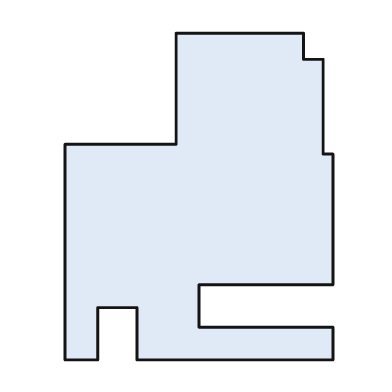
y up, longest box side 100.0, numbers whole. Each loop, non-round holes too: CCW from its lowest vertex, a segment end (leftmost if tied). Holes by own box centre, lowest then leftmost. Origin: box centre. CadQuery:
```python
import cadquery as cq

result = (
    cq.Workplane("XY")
    .moveTo(-41.0, -50.0)
    .lineTo(-31.0, -50.0)
    .lineTo(-31.0, -34.0)
    .lineTo(-19.0, -34.0)
    .lineTo(-19.0, -50.0)
    .lineTo(41.0, -50.0)
    .lineTo(41.0, -40.0)
    .lineTo(0.0, -40.0)
    .lineTo(0.0, -27.0)
    .lineTo(41.0, -27.0)
    .lineTo(41.0, 13.0)
    .lineTo(38.0, 13.0)
    .lineTo(38.0, 42.0)
    .lineTo(32.0, 42.0)
    .lineTo(32.0, 50.0)
    .lineTo(-7.0, 50.0)
    .lineTo(-7.0, 16.0)
    .lineTo(-41.0, 16.0)
    .close()
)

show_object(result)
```